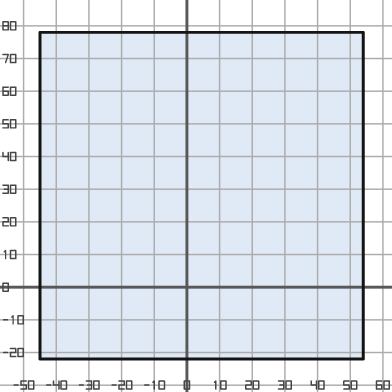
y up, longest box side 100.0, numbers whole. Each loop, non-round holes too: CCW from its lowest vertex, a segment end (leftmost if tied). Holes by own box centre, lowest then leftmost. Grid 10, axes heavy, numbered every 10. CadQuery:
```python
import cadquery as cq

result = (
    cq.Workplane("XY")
    .moveTo(-45.0, -22.0)
    .lineTo(54.0, -22.0)
    .lineTo(54.0, 78.0)
    .lineTo(-45.0, 78.0)
    .close()
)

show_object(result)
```